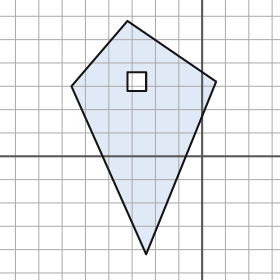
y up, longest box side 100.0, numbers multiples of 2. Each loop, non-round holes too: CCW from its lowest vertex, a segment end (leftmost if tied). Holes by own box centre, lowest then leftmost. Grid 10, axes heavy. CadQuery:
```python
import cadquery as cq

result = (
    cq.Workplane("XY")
    .moveTo(-24.0, -42.0)
    .lineTo(6.0, 32.0)
    .lineTo(-32.0, 58.0)
    .lineTo(-56.0, 30.0)
    .close()
    .moveTo(-32.0, 28.0)
    .lineTo(-24.0, 28.0)
    .lineTo(-24.0, 36.0)
    .lineTo(-32.0, 36.0)
    .close()
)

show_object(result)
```